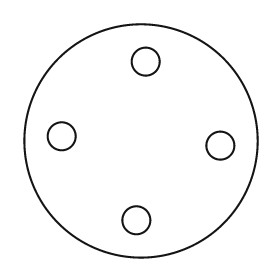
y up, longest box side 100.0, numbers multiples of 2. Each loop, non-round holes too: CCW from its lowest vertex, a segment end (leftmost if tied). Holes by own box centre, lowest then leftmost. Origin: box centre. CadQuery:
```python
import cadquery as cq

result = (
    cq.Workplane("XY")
    .moveTo(0.0, 0.0)
    .circle(50.0)
    .moveTo(-2.0, -34.0)
    .circle(6.0)
    .moveTo(34.0, -2.0)
    .circle(6.0)
    .moveTo(-34.0, 2.0)
    .circle(6.0)
    .moveTo(2.0, 34.0)
    .circle(6.0)
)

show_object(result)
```